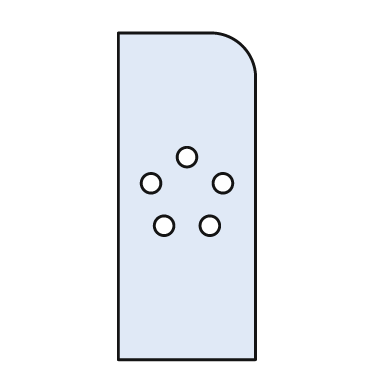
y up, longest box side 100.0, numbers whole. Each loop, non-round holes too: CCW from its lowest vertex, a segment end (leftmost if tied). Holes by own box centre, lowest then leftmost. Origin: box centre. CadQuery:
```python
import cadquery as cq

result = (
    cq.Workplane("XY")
    .moveTo(-21.0, -50.0)
    .lineTo(21.0, -50.0)
    .lineTo(21.0, 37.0)
    .threePointArc((17.0, 46.0), (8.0, 50.0))
    .lineTo(-21.0, 50.0)
    .close()
    .moveTo(-7.0, -9.0)
    .circle(3.0)
    .moveTo(7.0, -9.0)
    .circle(3.0)
    .moveTo(-11.0, 4.0)
    .circle(3.0)
    .moveTo(11.0, 4.0)
    .circle(3.0)
    .moveTo(0.0, 12.0)
    .circle(3.0)
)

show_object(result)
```